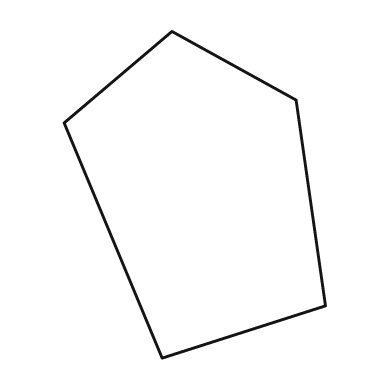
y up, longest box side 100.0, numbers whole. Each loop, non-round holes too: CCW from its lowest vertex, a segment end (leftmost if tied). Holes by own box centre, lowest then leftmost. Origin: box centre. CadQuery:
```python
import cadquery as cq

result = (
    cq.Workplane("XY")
    .moveTo(-10.0, -50.0)
    .lineTo(40.0, -34.0)
    .lineTo(31.0, 29.0)
    .lineTo(-7.0, 50.0)
    .lineTo(-40.0, 22.0)
    .close()
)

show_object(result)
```